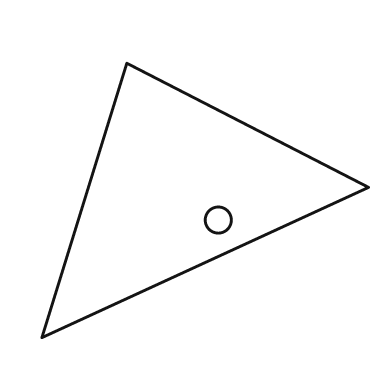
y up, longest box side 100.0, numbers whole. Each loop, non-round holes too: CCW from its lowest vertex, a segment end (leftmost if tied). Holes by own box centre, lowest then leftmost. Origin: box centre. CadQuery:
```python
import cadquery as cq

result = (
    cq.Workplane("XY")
    .moveTo(-50.0, -42.0)
    .lineTo(50.0, 4.0)
    .lineTo(-24.0, 42.0)
    .close()
    .moveTo(4.0, -6.0)
    .circle(4.0)
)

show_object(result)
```